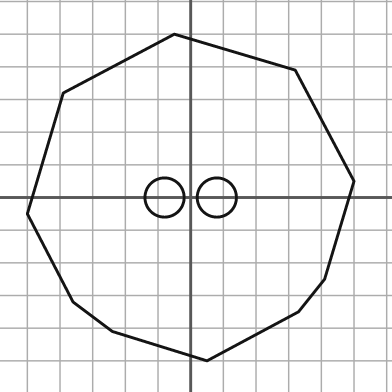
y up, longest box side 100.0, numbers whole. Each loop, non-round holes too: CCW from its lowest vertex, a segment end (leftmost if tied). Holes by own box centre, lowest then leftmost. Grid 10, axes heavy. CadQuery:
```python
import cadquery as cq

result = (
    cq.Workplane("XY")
    .moveTo(5.0, -50.0)
    .lineTo(33.0, -35.0)
    .lineTo(41.0, -25.0)
    .lineTo(50.0, 5.0)
    .lineTo(32.0, 39.0)
    .lineTo(-5.0, 50.0)
    .lineTo(-39.0, 32.0)
    .lineTo(-50.0, -5.0)
    .lineTo(-36.0, -32.0)
    .lineTo(-24.0, -41.0)
    .close()
    .moveTo(-8.0, 0.0)
    .circle(6.0)
    .moveTo(8.0, 0.0)
    .circle(6.0)
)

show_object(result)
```